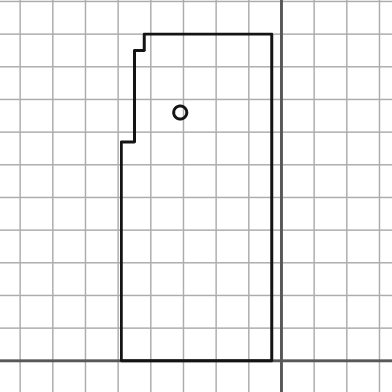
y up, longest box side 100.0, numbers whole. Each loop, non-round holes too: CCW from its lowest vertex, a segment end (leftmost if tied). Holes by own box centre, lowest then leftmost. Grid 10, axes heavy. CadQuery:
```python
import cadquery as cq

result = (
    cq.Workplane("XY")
    .moveTo(-49.0, 0.0)
    .lineTo(-3.0, 0.0)
    .lineTo(-3.0, 100.0)
    .lineTo(-42.0, 100.0)
    .lineTo(-42.0, 95.0)
    .lineTo(-45.0, 95.0)
    .lineTo(-45.0, 67.0)
    .lineTo(-49.0, 67.0)
    .close()
    .moveTo(-31.0, 76.0)
    .circle(2.0)
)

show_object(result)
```